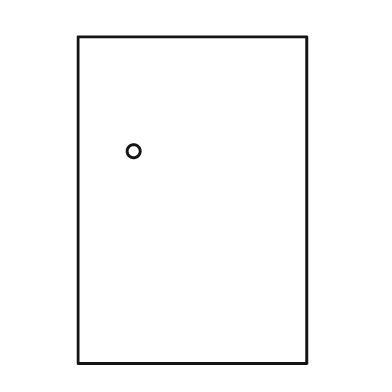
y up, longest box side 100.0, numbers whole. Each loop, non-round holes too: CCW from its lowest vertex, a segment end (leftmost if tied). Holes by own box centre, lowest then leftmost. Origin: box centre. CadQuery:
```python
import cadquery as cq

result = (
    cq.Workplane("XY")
    .moveTo(-35.0, -50.0)
    .lineTo(35.0, -50.0)
    .lineTo(35.0, 50.0)
    .lineTo(-35.0, 50.0)
    .close()
    .moveTo(-18.0, 15.0)
    .circle(2.0)
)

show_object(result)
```